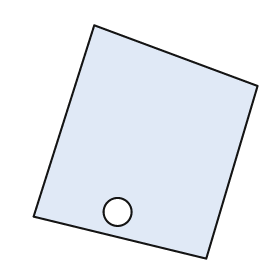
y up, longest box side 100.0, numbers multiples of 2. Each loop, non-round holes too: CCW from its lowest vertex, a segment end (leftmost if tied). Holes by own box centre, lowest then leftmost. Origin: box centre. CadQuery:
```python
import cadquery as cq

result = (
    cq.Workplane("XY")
    .moveTo(26.0, -50.0)
    .lineTo(48.0, 24.0)
    .lineTo(-22.0, 50.0)
    .lineTo(-48.0, -32.0)
    .close()
    .moveTo(-12.0, -30.0)
    .circle(6.0)
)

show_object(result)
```